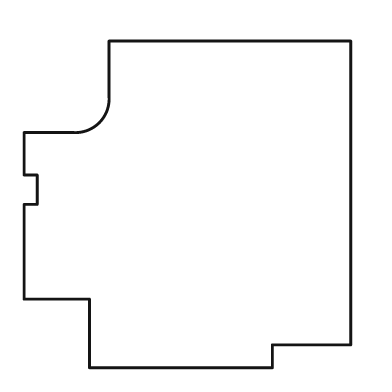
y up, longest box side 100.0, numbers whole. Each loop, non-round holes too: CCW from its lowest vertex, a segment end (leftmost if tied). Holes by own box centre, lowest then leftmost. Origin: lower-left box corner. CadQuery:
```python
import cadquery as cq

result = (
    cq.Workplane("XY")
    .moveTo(20.0, 0.0)
    .lineTo(76.0, 0.0)
    .lineTo(76.0, 7.0)
    .lineTo(100.0, 7.0)
    .lineTo(100.0, 100.0)
    .lineTo(26.0, 100.0)
    .lineTo(26.0, 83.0)
    .threePointArc((23.0, 75.0), (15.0, 72.0))
    .lineTo(0.0, 72.0)
    .lineTo(0.0, 59.0)
    .lineTo(4.0, 59.0)
    .lineTo(4.0, 50.0)
    .lineTo(0.0, 50.0)
    .lineTo(0.0, 21.0)
    .lineTo(20.0, 21.0)
    .close()
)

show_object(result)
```